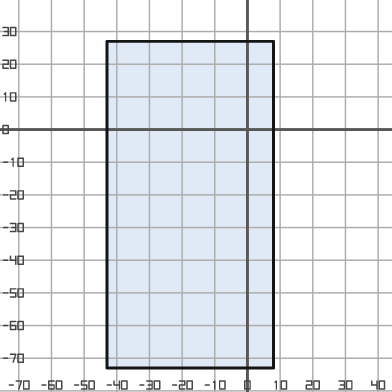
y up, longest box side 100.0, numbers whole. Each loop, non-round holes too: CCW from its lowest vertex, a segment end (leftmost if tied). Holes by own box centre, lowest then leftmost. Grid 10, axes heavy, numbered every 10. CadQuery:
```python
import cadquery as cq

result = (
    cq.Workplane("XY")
    .moveTo(-43.0, -73.0)
    .lineTo(8.0, -73.0)
    .lineTo(8.0, 27.0)
    .lineTo(-43.0, 27.0)
    .close()
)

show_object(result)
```